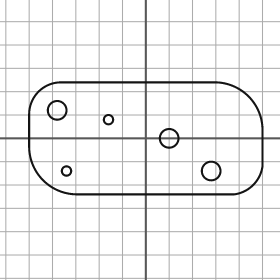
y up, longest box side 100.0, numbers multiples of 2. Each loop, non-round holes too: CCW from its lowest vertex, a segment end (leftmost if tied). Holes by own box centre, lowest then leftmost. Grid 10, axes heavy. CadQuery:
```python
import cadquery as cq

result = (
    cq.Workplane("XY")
    .moveTo(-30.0, -24.0)
    .lineTo(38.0, -24.0)
    .threePointArc((46.0, -20.0), (50.0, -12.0))
    .lineTo(50.0, 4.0)
    .threePointArc((44.0, 18.0), (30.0, 24.0))
    .lineTo(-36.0, 24.0)
    .threePointArc((-46.0, 20.0), (-50.0, 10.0))
    .lineTo(-50.0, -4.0)
    .threePointArc((-44.0, -18.0), (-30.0, -24.0))
    .close()
    .moveTo(-34.0, -14.0)
    .circle(2.0)
    .moveTo(28.0, -14.0)
    .circle(4.0)
    .moveTo(10.0, 0.0)
    .circle(4.0)
    .moveTo(-16.0, 8.0)
    .circle(2.0)
    .moveTo(-38.0, 12.0)
    .circle(4.0)
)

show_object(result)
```